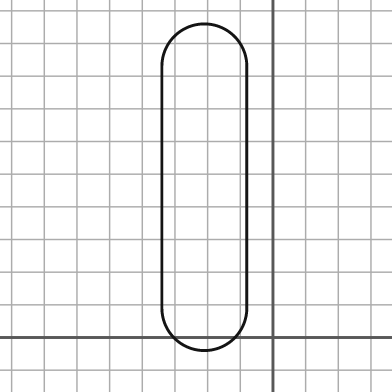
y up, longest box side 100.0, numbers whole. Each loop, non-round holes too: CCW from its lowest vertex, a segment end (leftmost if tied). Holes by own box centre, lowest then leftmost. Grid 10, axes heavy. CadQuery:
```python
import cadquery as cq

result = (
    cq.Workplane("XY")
    .moveTo(-34.0, 9.0)
    .threePointArc((-21.0, -4.0), (-8.0, 9.0))
    .lineTo(-8.0, 83.0)
    .threePointArc((-21.0, 96.0), (-34.0, 83.0))
    .close()
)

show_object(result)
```